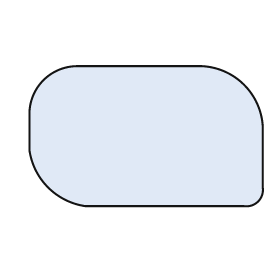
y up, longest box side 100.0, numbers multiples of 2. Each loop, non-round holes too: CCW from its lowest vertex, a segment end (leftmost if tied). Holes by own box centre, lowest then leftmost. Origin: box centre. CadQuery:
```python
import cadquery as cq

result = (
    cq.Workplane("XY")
    .moveTo(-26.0, -30.0)
    .lineTo(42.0, -30.0)
    .threePointArc((48.0, -28.0), (50.0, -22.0))
    .lineTo(50.0, 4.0)
    .threePointArc((42.0, 22.0), (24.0, 30.0))
    .lineTo(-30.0, 30.0)
    .threePointArc((-44.0, 24.0), (-50.0, 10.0))
    .lineTo(-50.0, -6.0)
    .threePointArc((-42.0, -22.0), (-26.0, -30.0))
    .close()
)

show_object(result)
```